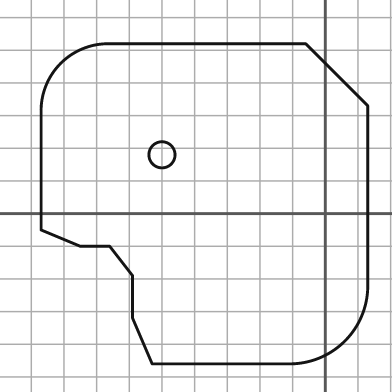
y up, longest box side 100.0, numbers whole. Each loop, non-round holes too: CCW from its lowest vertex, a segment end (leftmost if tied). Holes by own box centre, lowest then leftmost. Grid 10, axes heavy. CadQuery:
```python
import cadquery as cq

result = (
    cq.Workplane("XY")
    .moveTo(-53.0, -46.0)
    .lineTo(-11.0, -46.0)
    .threePointArc((6.0, -39.0), (13.0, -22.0))
    .lineTo(13.0, 33.0)
    .lineTo(-6.0, 52.0)
    .lineTo(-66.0, 52.0)
    .threePointArc((-81.0, 46.0), (-87.0, 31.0))
    .lineTo(-87.0, -5.0)
    .lineTo(-75.0, -10.0)
    .lineTo(-66.0, -10.0)
    .lineTo(-59.0, -19.0)
    .lineTo(-59.0, -32.0)
    .close()
    .moveTo(-50.0, 18.0)
    .circle(4.0)
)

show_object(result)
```